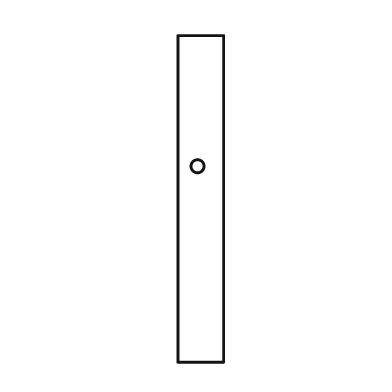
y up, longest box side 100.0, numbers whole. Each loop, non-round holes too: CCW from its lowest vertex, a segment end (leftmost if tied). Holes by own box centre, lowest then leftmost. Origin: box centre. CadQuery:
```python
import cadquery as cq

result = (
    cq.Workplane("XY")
    .moveTo(-7.0, -50.0)
    .lineTo(7.0, -50.0)
    .lineTo(7.0, 50.0)
    .lineTo(-7.0, 50.0)
    .close()
    .moveTo(-1.0, 10.0)
    .circle(2.0)
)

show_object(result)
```